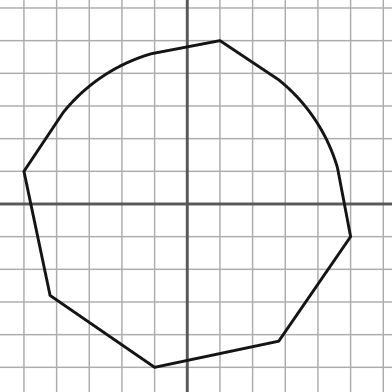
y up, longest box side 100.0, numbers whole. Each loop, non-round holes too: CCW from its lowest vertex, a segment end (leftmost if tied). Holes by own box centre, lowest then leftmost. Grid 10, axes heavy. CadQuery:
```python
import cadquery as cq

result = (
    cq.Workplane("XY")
    .moveTo(-10.0, -50.0)
    .lineTo(28.0, -42.0)
    .lineTo(50.0, -10.0)
    .lineTo(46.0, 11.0)
    .threePointArc((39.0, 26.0), (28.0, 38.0))
    .lineTo(10.0, 50.0)
    .lineTo(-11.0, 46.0)
    .threePointArc((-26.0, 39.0), (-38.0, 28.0))
    .lineTo(-50.0, 10.0)
    .lineTo(-42.0, -28.0)
    .close()
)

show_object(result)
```